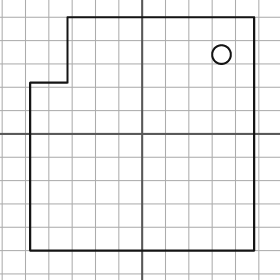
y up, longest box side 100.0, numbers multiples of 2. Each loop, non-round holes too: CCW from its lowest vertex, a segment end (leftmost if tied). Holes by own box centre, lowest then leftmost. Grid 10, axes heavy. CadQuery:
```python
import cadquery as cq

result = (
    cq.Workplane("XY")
    .moveTo(-48.0, -50.0)
    .lineTo(48.0, -50.0)
    .lineTo(48.0, 50.0)
    .lineTo(-32.0, 50.0)
    .lineTo(-32.0, 22.0)
    .lineTo(-48.0, 22.0)
    .close()
    .moveTo(34.0, 34.0)
    .circle(4.0)
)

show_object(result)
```